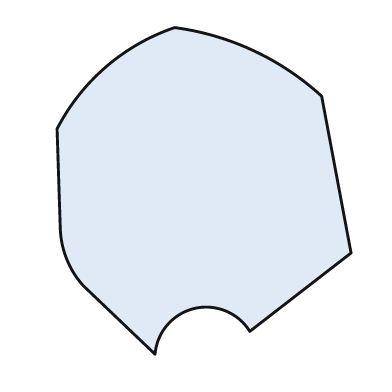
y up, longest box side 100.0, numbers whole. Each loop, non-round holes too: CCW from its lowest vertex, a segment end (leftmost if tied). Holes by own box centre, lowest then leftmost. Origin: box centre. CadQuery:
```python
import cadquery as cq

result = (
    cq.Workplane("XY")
    .moveTo(-15.0, -50.0)
    .threePointArc((-3.0, -36.0), (14.0, -43.0))
    .lineTo(45.0, -19.0)
    .lineTo(36.0, 29.0)
    .threePointArc((15.0, 43.0), (-9.0, 50.0))
    .threePointArc((-30.0, 38.0), (-45.0, 19.0))
    .lineTo(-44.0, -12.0)
    .threePointArc((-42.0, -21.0), (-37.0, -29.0))
    .close()
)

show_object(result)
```